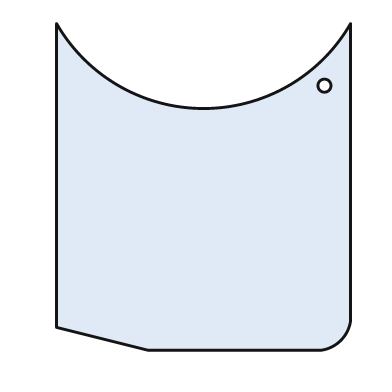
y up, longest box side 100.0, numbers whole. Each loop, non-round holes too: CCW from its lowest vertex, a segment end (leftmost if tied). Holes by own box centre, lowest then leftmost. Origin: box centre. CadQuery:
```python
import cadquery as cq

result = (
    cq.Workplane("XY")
    .moveTo(-17.0, -50.0)
    .lineTo(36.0, -50.0)
    .threePointArc((42.0, -47.0), (45.0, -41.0))
    .lineTo(45.0, 50.0)
    .threePointArc((0.0, 24.0), (-45.0, 50.0))
    .lineTo(-45.0, -43.0)
    .close()
    .moveTo(37.0, 31.0)
    .circle(2.0)
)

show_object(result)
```